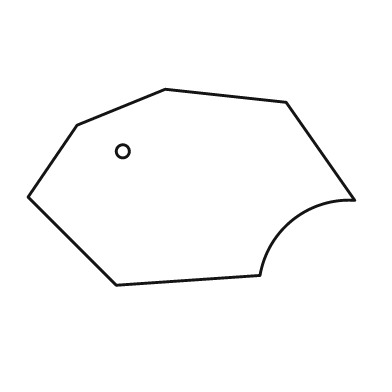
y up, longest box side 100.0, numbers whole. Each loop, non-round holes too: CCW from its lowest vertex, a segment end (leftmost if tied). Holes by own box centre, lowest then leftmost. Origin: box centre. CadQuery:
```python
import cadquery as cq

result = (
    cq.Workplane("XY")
    .moveTo(-23.0, -30.0)
    .lineTo(21.0, -27.0)
    .threePointArc((31.0, -10.0), (50.0, -4.0))
    .lineTo(29.0, 26.0)
    .lineTo(-8.0, 30.0)
    .lineTo(-35.0, 19.0)
    .lineTo(-50.0, -3.0)
    .close()
    .moveTo(-21.0, 11.0)
    .circle(2.0)
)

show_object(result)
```